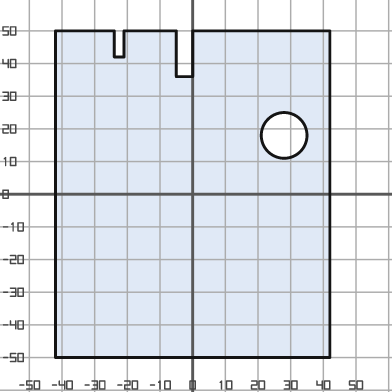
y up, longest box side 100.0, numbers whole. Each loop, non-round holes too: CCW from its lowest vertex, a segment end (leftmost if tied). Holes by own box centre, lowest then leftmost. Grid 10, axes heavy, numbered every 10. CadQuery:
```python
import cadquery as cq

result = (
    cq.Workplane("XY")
    .moveTo(-42.0, -50.0)
    .lineTo(42.0, -50.0)
    .lineTo(42.0, 50.0)
    .lineTo(0.0, 50.0)
    .lineTo(0.0, 36.0)
    .lineTo(-5.0, 36.0)
    .lineTo(-5.0, 50.0)
    .lineTo(-21.0, 50.0)
    .lineTo(-21.0, 42.0)
    .lineTo(-24.0, 42.0)
    .lineTo(-24.0, 50.0)
    .lineTo(-42.0, 50.0)
    .close()
    .moveTo(28.0, 18.0)
    .circle(7.0)
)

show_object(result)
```